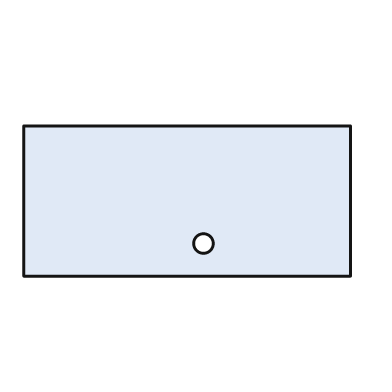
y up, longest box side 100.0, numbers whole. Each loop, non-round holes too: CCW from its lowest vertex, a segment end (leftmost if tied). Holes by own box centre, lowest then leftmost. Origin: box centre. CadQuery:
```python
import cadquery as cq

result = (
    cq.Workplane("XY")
    .moveTo(-50.0, -23.0)
    .lineTo(50.0, -23.0)
    .lineTo(50.0, 23.0)
    .lineTo(-50.0, 23.0)
    .close()
    .moveTo(5.0, -13.0)
    .circle(3.0)
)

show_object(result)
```